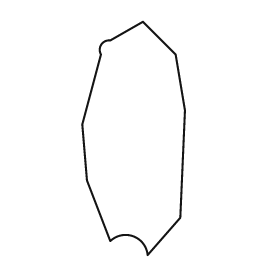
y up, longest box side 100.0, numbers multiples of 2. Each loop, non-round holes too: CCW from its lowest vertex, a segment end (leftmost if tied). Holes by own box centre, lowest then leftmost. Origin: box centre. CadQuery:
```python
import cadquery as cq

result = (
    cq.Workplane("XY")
    .moveTo(6.0, -50.0)
    .lineTo(20.0, -34.0)
    .lineTo(22.0, 12.0)
    .lineTo(18.0, 36.0)
    .lineTo(4.0, 50.0)
    .lineTo(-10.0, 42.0)
    .threePointArc((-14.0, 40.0), (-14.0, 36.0))
    .lineTo(-22.0, 6.0)
    .lineTo(-20.0, -18.0)
    .lineTo(-10.0, -44.0)
    .threePointArc((0.0, -42.0), (6.0, -50.0))
    .close()
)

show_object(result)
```